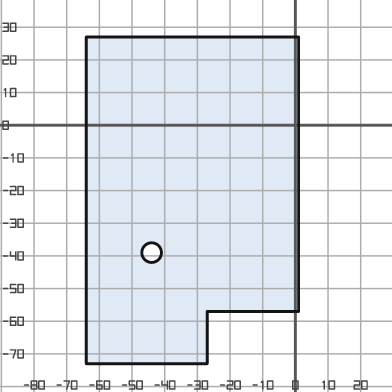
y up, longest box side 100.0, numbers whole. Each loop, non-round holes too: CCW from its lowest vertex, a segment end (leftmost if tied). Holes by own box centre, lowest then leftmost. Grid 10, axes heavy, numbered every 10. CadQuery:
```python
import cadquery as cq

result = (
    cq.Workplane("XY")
    .moveTo(-64.0, -73.0)
    .lineTo(-27.0, -73.0)
    .lineTo(-27.0, -57.0)
    .lineTo(1.0, -57.0)
    .lineTo(1.0, 27.0)
    .lineTo(-64.0, 27.0)
    .close()
    .moveTo(-44.0, -39.0)
    .circle(3.0)
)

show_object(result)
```